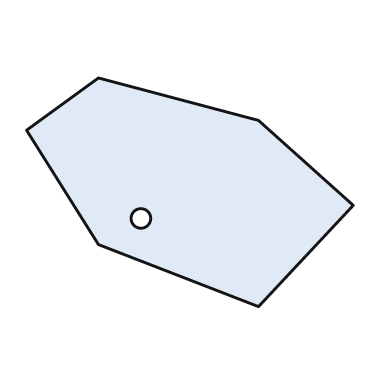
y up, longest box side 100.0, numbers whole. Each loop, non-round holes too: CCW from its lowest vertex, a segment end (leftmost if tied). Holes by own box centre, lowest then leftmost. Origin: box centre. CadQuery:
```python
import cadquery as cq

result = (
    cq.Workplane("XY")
    .moveTo(21.0, -35.0)
    .lineTo(50.0, -4.0)
    .lineTo(21.0, 22.0)
    .lineTo(-28.0, 35.0)
    .lineTo(-50.0, 19.0)
    .lineTo(-28.0, -16.0)
    .close()
    .moveTo(-15.0, -8.0)
    .circle(3.0)
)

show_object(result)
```